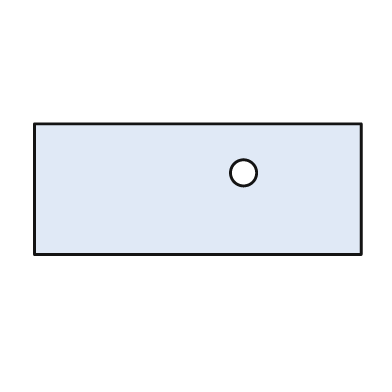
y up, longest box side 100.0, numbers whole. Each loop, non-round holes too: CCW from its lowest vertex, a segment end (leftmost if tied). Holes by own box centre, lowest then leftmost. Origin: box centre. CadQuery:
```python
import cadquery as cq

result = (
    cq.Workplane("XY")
    .moveTo(-50.0, -20.0)
    .lineTo(50.0, -20.0)
    .lineTo(50.0, 20.0)
    .lineTo(-50.0, 20.0)
    .close()
    .moveTo(14.0, 5.0)
    .circle(4.0)
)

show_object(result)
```